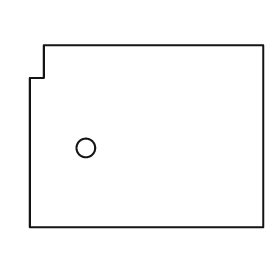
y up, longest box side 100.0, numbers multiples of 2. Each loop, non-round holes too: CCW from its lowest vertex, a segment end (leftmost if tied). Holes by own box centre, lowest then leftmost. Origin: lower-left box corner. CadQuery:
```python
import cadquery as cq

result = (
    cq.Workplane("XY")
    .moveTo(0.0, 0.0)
    .lineTo(100.0, 0.0)
    .lineTo(100.0, 78.0)
    .lineTo(6.0, 78.0)
    .lineTo(6.0, 64.0)
    .lineTo(0.0, 64.0)
    .close()
    .moveTo(24.0, 34.0)
    .circle(4.0)
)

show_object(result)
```